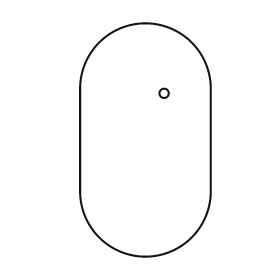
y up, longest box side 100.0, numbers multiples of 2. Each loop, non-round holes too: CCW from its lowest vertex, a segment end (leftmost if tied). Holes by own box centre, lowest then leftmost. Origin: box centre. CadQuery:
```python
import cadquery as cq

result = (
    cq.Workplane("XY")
    .moveTo(-28.0, -22.0)
    .threePointArc((0.0, -50.0), (28.0, -22.0))
    .lineTo(28.0, 22.0)
    .threePointArc((0.0, 50.0), (-28.0, 22.0))
    .close()
    .moveTo(8.0, 20.0)
    .circle(2.0)
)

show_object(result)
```